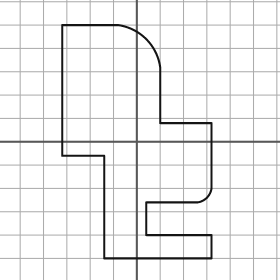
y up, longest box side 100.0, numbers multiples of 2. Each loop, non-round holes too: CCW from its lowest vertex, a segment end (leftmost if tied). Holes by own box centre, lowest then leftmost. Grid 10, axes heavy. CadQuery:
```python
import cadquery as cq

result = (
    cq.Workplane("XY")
    .moveTo(-14.0, -50.0)
    .lineTo(32.0, -50.0)
    .lineTo(32.0, -40.0)
    .lineTo(4.0, -40.0)
    .lineTo(4.0, -26.0)
    .lineTo(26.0, -26.0)
    .threePointArc((30.0, -24.0), (32.0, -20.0))
    .lineTo(32.0, 8.0)
    .lineTo(10.0, 8.0)
    .lineTo(10.0, 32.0)
    .threePointArc((4.0, 44.0), (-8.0, 50.0))
    .lineTo(-32.0, 50.0)
    .lineTo(-32.0, -6.0)
    .lineTo(-14.0, -6.0)
    .close()
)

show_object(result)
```